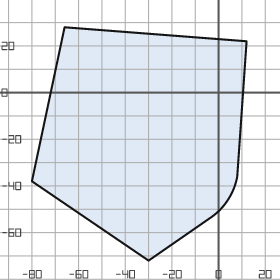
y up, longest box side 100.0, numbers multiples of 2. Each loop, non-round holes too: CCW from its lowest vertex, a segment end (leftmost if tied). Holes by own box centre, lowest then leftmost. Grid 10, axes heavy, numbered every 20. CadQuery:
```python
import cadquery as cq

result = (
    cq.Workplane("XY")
    .moveTo(-30.0, -72.0)
    .lineTo(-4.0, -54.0)
    .threePointArc((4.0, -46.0), (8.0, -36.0))
    .lineTo(12.0, 22.0)
    .lineTo(-66.0, 28.0)
    .lineTo(-80.0, -38.0)
    .close()
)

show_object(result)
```